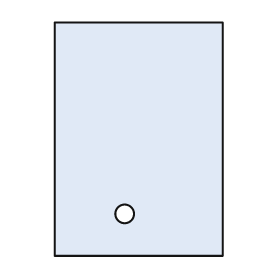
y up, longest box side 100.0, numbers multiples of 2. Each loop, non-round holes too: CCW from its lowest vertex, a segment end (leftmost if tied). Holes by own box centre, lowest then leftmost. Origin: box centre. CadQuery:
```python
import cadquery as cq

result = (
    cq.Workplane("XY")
    .moveTo(-36.0, -50.0)
    .lineTo(36.0, -50.0)
    .lineTo(36.0, 50.0)
    .lineTo(-36.0, 50.0)
    .close()
    .moveTo(-6.0, -32.0)
    .circle(4.0)
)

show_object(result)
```